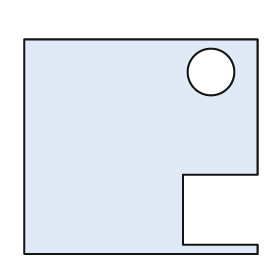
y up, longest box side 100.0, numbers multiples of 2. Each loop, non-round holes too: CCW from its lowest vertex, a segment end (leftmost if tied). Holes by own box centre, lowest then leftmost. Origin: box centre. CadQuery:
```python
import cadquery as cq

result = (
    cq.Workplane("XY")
    .moveTo(-50.0, -46.0)
    .lineTo(50.0, -46.0)
    .lineTo(50.0, -42.0)
    .lineTo(18.0, -42.0)
    .lineTo(18.0, -12.0)
    .lineTo(50.0, -12.0)
    .lineTo(50.0, 46.0)
    .lineTo(-50.0, 46.0)
    .close()
    .moveTo(30.0, 32.0)
    .circle(10.0)
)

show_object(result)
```